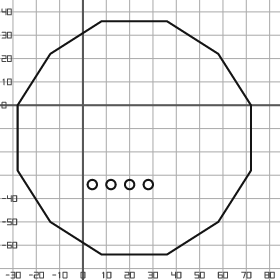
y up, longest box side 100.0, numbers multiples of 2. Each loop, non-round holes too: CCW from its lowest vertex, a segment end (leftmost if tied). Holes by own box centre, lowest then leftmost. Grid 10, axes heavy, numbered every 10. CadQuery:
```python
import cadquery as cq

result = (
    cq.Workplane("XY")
    .moveTo(8.0, -64.0)
    .lineTo(36.0, -64.0)
    .lineTo(58.0, -50.0)
    .lineTo(72.0, -28.0)
    .lineTo(72.0, 0.0)
    .lineTo(58.0, 22.0)
    .lineTo(36.0, 36.0)
    .lineTo(8.0, 36.0)
    .lineTo(-14.0, 22.0)
    .lineTo(-28.0, 0.0)
    .lineTo(-28.0, -28.0)
    .lineTo(-14.0, -50.0)
    .close()
    .moveTo(4.0, -34.0)
    .circle(2.0)
    .moveTo(12.0, -34.0)
    .circle(2.0)
    .moveTo(20.0, -34.0)
    .circle(2.0)
    .moveTo(28.0, -34.0)
    .circle(2.0)
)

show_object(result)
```